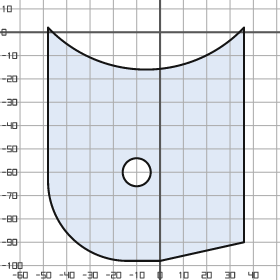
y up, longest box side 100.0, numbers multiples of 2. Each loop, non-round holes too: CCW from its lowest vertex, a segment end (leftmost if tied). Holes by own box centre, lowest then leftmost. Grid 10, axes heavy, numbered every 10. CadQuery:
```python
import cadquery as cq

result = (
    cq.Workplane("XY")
    .moveTo(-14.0, -98.0)
    .lineTo(0.0, -98.0)
    .lineTo(36.0, -90.0)
    .lineTo(36.0, 2.0)
    .threePointArc((-6.0, -16.0), (-48.0, 2.0))
    .lineTo(-48.0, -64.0)
    .threePointArc((-38.0, -88.0), (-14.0, -98.0))
    .close()
    .moveTo(-10.0, -60.0)
    .circle(6.0)
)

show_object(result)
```